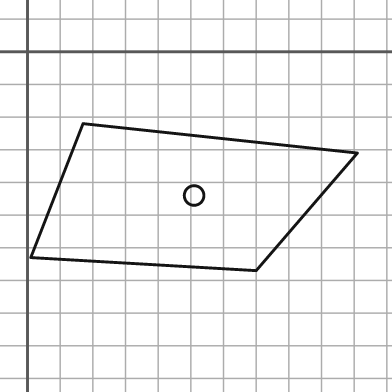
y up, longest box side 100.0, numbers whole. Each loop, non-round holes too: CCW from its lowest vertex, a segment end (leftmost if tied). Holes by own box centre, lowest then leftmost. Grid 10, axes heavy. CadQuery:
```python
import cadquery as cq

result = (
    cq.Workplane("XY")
    .moveTo(70.0, -67.0)
    .lineTo(101.0, -31.0)
    .lineTo(17.0, -22.0)
    .lineTo(1.0, -63.0)
    .close()
    .moveTo(51.0, -44.0)
    .circle(3.0)
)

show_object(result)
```